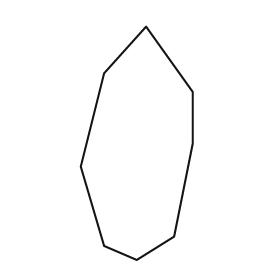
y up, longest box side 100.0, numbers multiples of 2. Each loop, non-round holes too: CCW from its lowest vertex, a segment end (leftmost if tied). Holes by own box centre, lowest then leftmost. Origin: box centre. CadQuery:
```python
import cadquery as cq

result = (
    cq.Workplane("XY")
    .moveTo(0.0, -50.0)
    .lineTo(16.0, -40.0)
    .lineTo(24.0, 0.0)
    .lineTo(24.0, 22.0)
    .lineTo(4.0, 50.0)
    .lineTo(-14.0, 30.0)
    .lineTo(-24.0, -10.0)
    .lineTo(-14.0, -44.0)
    .close()
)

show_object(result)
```